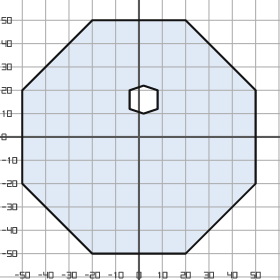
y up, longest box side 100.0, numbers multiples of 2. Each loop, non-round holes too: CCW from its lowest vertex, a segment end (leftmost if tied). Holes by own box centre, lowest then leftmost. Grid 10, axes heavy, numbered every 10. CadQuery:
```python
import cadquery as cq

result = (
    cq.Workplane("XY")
    .moveTo(-20.0, -50.0)
    .lineTo(20.0, -50.0)
    .lineTo(50.0, -20.0)
    .lineTo(50.0, 20.0)
    .lineTo(20.0, 50.0)
    .lineTo(-20.0, 50.0)
    .lineTo(-50.0, 20.0)
    .lineTo(-50.0, -20.0)
    .close()
    .moveTo(2.0, 10.0)
    .lineTo(8.0, 12.0)
    .lineTo(8.0, 20.0)
    .lineTo(2.0, 22.0)
    .lineTo(-4.0, 20.0)
    .lineTo(-4.0, 12.0)
    .close()
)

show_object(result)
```